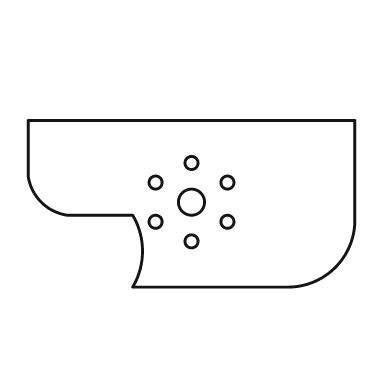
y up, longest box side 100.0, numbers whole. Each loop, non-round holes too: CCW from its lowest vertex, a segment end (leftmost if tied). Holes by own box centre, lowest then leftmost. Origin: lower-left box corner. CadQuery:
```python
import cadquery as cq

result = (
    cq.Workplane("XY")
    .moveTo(32.0, 0.0)
    .lineTo(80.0, 0.0)
    .threePointArc((94.0, 6.0), (100.0, 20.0))
    .lineTo(100.0, 51.0)
    .lineTo(0.0, 51.0)
    .lineTo(0.0, 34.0)
    .threePointArc((4.0, 26.0), (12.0, 22.0))
    .lineTo(32.0, 22.0)
    .threePointArc((35.0, 11.0), (32.0, 0.0))
    .close()
    .moveTo(50.0, 14.0)
    .circle(2.0)
    .moveTo(39.0, 20.0)
    .circle(2.0)
    .moveTo(61.0, 20.0)
    .circle(2.0)
    .moveTo(50.0, 26.0)
    .circle(4.0)
    .moveTo(39.0, 32.0)
    .circle(2.0)
    .moveTo(61.0, 32.0)
    .circle(2.0)
    .moveTo(50.0, 38.0)
    .circle(2.0)
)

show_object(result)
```